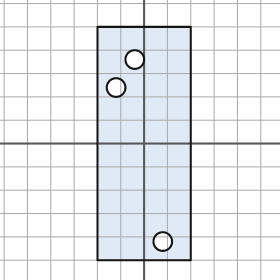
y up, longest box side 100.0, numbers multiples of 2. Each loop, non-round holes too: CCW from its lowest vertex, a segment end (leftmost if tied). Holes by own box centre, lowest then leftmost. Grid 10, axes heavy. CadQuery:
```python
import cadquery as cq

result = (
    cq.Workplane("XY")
    .moveTo(-20.0, -50.0)
    .lineTo(20.0, -50.0)
    .lineTo(20.0, 50.0)
    .lineTo(-20.0, 50.0)
    .close()
    .moveTo(8.0, -42.0)
    .circle(4.0)
    .moveTo(-12.0, 24.0)
    .circle(4.0)
    .moveTo(-4.0, 36.0)
    .circle(4.0)
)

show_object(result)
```